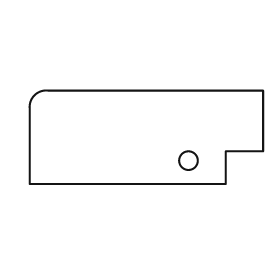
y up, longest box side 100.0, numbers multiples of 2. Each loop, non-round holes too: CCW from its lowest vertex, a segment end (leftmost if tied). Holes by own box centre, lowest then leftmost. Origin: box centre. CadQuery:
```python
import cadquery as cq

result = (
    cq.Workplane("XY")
    .moveTo(-50.0, -20.0)
    .lineTo(34.0, -20.0)
    .lineTo(34.0, -6.0)
    .lineTo(50.0, -6.0)
    .lineTo(50.0, 20.0)
    .lineTo(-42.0, 20.0)
    .threePointArc((-48.0, 18.0), (-50.0, 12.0))
    .close()
    .moveTo(18.0, -10.0)
    .circle(4.0)
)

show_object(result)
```